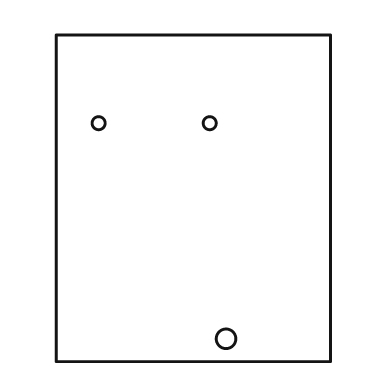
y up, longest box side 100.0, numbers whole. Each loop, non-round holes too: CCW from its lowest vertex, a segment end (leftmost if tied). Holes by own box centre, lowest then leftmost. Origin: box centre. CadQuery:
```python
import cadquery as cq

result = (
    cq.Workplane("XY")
    .moveTo(-42.0, -50.0)
    .lineTo(42.0, -50.0)
    .lineTo(42.0, 50.0)
    .lineTo(-42.0, 50.0)
    .close()
    .moveTo(10.0, -43.0)
    .circle(3.0)
    .moveTo(-29.0, 23.0)
    .circle(2.0)
    .moveTo(5.0, 23.0)
    .circle(2.0)
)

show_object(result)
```